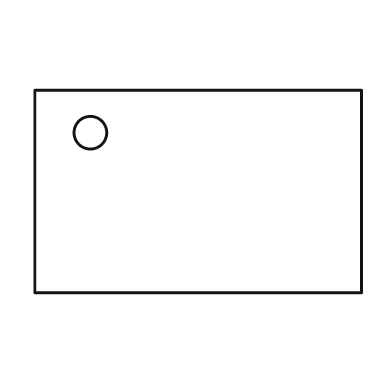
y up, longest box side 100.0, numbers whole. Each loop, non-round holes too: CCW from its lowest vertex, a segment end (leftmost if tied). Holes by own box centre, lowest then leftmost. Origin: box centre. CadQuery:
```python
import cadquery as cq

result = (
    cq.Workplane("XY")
    .moveTo(-50.0, -31.0)
    .lineTo(50.0, -31.0)
    .lineTo(50.0, 31.0)
    .lineTo(-50.0, 31.0)
    .close()
    .moveTo(-33.0, 18.0)
    .circle(5.0)
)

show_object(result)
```